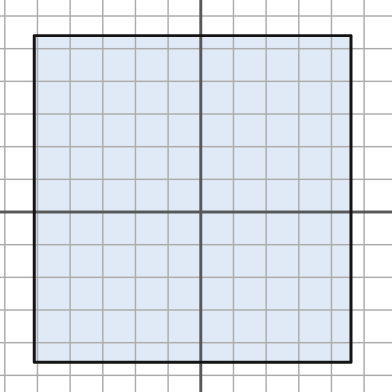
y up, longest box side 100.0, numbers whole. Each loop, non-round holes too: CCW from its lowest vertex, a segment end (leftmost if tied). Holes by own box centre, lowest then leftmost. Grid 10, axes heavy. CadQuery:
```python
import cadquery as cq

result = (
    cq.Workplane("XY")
    .moveTo(-51.0, -46.0)
    .lineTo(46.0, -46.0)
    .lineTo(46.0, 54.0)
    .lineTo(-51.0, 54.0)
    .close()
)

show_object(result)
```